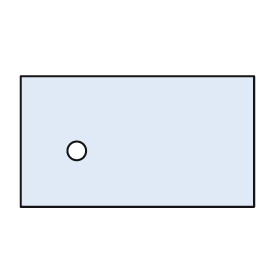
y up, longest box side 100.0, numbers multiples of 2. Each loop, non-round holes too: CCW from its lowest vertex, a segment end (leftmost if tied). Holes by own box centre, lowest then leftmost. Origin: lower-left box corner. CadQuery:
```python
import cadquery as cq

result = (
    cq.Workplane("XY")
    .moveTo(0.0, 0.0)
    .lineTo(100.0, 0.0)
    .lineTo(100.0, 56.0)
    .lineTo(0.0, 56.0)
    .close()
    .moveTo(24.0, 24.0)
    .circle(4.0)
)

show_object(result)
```